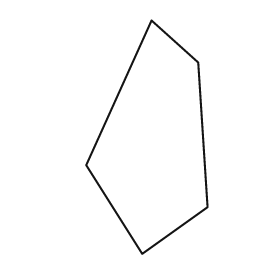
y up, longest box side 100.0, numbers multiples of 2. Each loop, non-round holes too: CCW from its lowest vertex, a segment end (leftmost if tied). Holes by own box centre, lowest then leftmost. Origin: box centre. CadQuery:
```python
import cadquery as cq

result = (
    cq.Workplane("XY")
    .moveTo(-2.0, -50.0)
    .lineTo(26.0, -30.0)
    .lineTo(22.0, 32.0)
    .lineTo(2.0, 50.0)
    .lineTo(-26.0, -12.0)
    .close()
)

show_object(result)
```